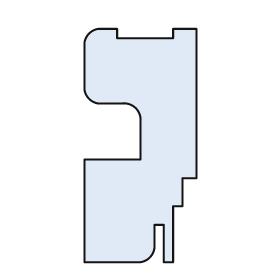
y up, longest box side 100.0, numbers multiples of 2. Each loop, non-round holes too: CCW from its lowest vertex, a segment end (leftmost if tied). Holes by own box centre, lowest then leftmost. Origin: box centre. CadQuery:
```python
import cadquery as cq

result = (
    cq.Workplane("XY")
    .moveTo(-24.0, -50.0)
    .lineTo(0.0, -50.0)
    .threePointArc((4.0, -48.0), (6.0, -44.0))
    .lineTo(6.0, -34.0)
    .lineTo(10.0, -34.0)
    .lineTo(10.0, -50.0)
    .lineTo(14.0, -50.0)
    .lineTo(14.0, -26.0)
    .lineTo(18.0, -26.0)
    .lineTo(18.0, -14.0)
    .lineTo(24.0, -14.0)
    .lineTo(24.0, 50.0)
    .lineTo(14.0, 50.0)
    .lineTo(14.0, 46.0)
    .lineTo(-10.0, 46.0)
    .lineTo(-10.0, 50.0)
    .lineTo(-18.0, 50.0)
    .threePointArc((-22.0, 48.0), (-24.0, 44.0))
    .lineTo(-24.0, 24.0)
    .threePointArc((-22.0, 20.0), (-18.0, 18.0))
    .lineTo(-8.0, 18.0)
    .threePointArc((-2.0, 16.0), (0.0, 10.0))
    .lineTo(0.0, -6.0)
    .lineTo(-24.0, -6.0)
    .close()
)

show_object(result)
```